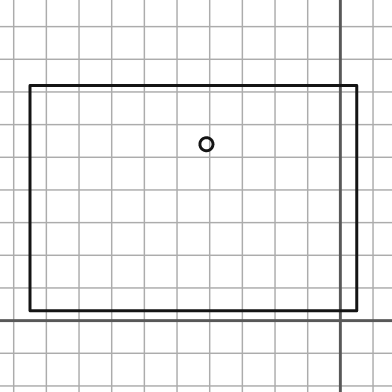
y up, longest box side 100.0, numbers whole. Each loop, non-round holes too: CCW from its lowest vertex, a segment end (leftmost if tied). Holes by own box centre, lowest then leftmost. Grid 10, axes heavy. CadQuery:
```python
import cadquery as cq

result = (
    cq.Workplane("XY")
    .moveTo(-95.0, 3.0)
    .lineTo(5.0, 3.0)
    .lineTo(5.0, 72.0)
    .lineTo(-95.0, 72.0)
    .close()
    .moveTo(-41.0, 54.0)
    .circle(2.0)
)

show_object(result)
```